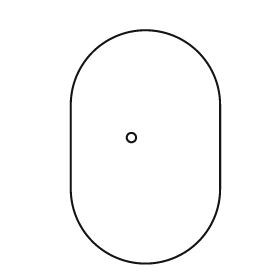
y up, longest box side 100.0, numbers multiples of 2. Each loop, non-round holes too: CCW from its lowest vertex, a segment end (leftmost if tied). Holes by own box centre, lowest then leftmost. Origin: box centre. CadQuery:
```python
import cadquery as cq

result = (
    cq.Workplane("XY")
    .moveTo(-32.0, -18.0)
    .threePointArc((0.0, -50.0), (32.0, -18.0))
    .lineTo(32.0, 18.0)
    .threePointArc((0.0, 50.0), (-32.0, 18.0))
    .close()
    .moveTo(-6.0, 4.0)
    .circle(2.0)
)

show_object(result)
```